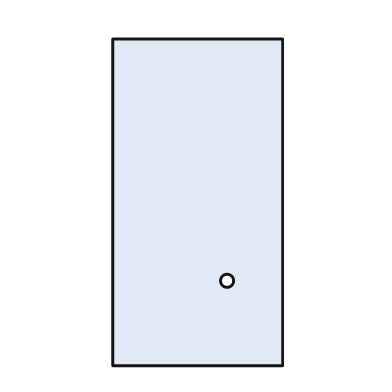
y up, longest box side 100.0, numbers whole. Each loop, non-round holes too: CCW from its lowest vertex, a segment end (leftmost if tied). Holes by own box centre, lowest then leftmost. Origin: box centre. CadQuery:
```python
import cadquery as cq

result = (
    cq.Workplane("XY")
    .moveTo(-26.0, -50.0)
    .lineTo(26.0, -50.0)
    .lineTo(26.0, 50.0)
    .lineTo(-26.0, 50.0)
    .close()
    .moveTo(9.0, -24.0)
    .circle(2.0)
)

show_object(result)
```